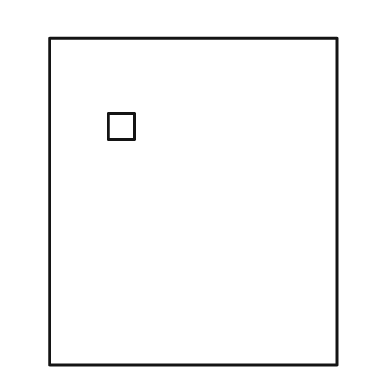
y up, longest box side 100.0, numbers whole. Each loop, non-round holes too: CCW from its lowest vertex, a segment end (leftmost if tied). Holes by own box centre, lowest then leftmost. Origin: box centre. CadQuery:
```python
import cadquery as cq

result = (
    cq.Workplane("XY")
    .moveTo(-44.0, -50.0)
    .lineTo(44.0, -50.0)
    .lineTo(44.0, 50.0)
    .lineTo(-44.0, 50.0)
    .close()
    .moveTo(-26.0, 19.0)
    .lineTo(-18.0, 19.0)
    .lineTo(-18.0, 27.0)
    .lineTo(-26.0, 27.0)
    .close()
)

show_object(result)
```